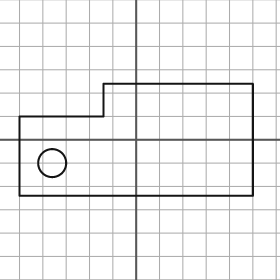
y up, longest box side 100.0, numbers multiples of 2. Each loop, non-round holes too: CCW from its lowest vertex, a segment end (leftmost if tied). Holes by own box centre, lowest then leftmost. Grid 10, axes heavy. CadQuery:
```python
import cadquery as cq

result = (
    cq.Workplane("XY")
    .moveTo(-50.0, -24.0)
    .lineTo(50.0, -24.0)
    .lineTo(50.0, 24.0)
    .lineTo(-14.0, 24.0)
    .lineTo(-14.0, 10.0)
    .lineTo(-50.0, 10.0)
    .close()
    .moveTo(-36.0, -10.0)
    .circle(6.0)
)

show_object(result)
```